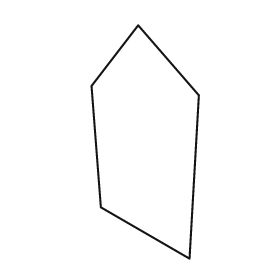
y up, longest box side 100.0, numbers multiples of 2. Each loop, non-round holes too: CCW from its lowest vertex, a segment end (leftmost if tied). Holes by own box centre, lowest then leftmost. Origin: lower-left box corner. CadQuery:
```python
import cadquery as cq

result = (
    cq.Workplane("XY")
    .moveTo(42.0, 0.0)
    .lineTo(46.0, 70.0)
    .lineTo(20.0, 100.0)
    .lineTo(0.0, 74.0)
    .lineTo(4.0, 22.0)
    .close()
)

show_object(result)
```